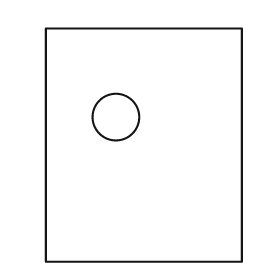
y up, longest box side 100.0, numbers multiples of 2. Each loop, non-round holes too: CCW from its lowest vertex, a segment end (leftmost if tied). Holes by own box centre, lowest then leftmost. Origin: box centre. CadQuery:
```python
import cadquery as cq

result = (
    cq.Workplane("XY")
    .moveTo(-42.0, -50.0)
    .lineTo(42.0, -50.0)
    .lineTo(42.0, 50.0)
    .lineTo(-42.0, 50.0)
    .close()
    .moveTo(-12.0, 12.0)
    .circle(10.0)
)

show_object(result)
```